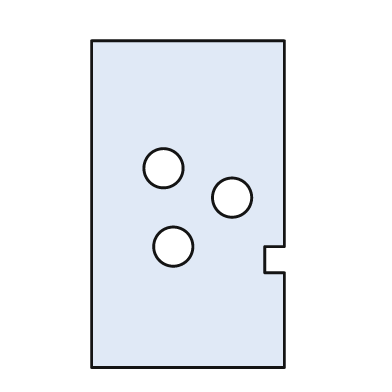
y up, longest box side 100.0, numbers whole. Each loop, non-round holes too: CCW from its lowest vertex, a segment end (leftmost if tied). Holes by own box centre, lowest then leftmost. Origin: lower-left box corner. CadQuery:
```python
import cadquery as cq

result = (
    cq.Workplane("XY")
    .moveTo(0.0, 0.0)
    .lineTo(59.0, 0.0)
    .lineTo(59.0, 29.0)
    .lineTo(53.0, 29.0)
    .lineTo(53.0, 37.0)
    .lineTo(59.0, 37.0)
    .lineTo(59.0, 100.0)
    .lineTo(0.0, 100.0)
    .close()
    .moveTo(25.0, 37.0)
    .circle(6.0)
    .moveTo(43.0, 52.0)
    .circle(6.0)
    .moveTo(22.0, 61.0)
    .circle(6.0)
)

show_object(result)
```